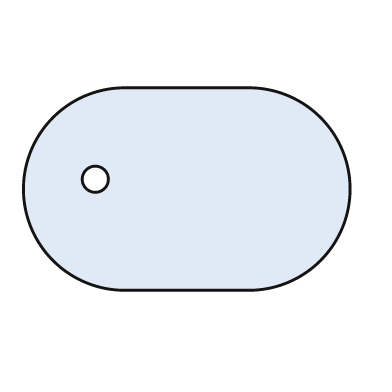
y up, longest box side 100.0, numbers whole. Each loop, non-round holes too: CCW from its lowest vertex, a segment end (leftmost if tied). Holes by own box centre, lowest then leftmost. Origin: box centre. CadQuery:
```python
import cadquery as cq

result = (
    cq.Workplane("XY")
    .moveTo(-19.0, -31.0)
    .lineTo(19.0, -31.0)
    .threePointArc((50.0, 0.0), (19.0, 31.0))
    .lineTo(-19.0, 31.0)
    .threePointArc((-50.0, 0.0), (-19.0, -31.0))
    .close()
    .moveTo(-28.0, 3.0)
    .circle(4.0)
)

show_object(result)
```